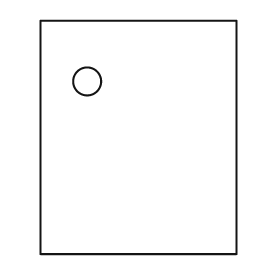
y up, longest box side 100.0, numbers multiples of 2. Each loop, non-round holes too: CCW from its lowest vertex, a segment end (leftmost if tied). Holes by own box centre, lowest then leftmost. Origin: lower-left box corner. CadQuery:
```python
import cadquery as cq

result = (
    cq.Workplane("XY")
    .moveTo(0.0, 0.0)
    .lineTo(84.0, 0.0)
    .lineTo(84.0, 100.0)
    .lineTo(0.0, 100.0)
    .close()
    .moveTo(20.0, 74.0)
    .circle(6.0)
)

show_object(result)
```